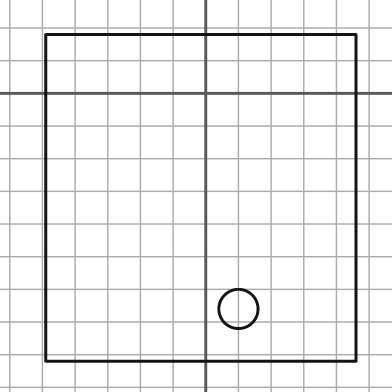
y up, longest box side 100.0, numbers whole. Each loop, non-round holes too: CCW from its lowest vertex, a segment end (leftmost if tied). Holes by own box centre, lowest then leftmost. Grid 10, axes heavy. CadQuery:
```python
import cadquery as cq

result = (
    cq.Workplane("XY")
    .moveTo(-49.0, -82.0)
    .lineTo(46.0, -82.0)
    .lineTo(46.0, 18.0)
    .lineTo(-49.0, 18.0)
    .close()
    .moveTo(10.0, -66.0)
    .circle(6.0)
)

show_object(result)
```